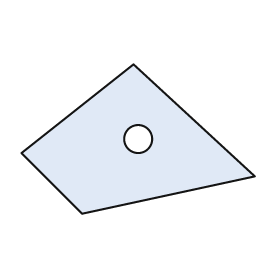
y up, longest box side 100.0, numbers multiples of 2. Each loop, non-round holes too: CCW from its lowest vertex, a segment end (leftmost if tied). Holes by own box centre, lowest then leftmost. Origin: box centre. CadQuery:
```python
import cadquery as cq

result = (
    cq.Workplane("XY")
    .moveTo(-24.0, -32.0)
    .lineTo(50.0, -16.0)
    .lineTo(-2.0, 32.0)
    .lineTo(-50.0, -6.0)
    .close()
    .moveTo(0.0, 0.0)
    .circle(6.0)
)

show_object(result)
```